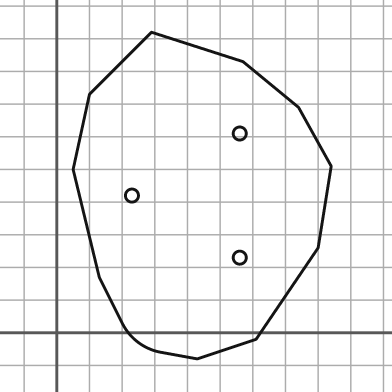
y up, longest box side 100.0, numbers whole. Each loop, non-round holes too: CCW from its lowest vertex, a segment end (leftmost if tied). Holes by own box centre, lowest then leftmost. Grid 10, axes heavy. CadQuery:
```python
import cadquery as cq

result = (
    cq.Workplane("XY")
    .moveTo(43.0, -8.0)
    .lineTo(61.0, -2.0)
    .lineTo(80.0, 26.0)
    .lineTo(84.0, 51.0)
    .lineTo(74.0, 69.0)
    .lineTo(57.0, 83.0)
    .lineTo(29.0, 92.0)
    .lineTo(10.0, 73.0)
    .lineTo(5.0, 50.0)
    .lineTo(13.0, 17.0)
    .lineTo(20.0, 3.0)
    .threePointArc((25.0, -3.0), (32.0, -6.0))
    .close()
    .moveTo(56.0, 23.0)
    .circle(2.0)
    .moveTo(23.0, 42.0)
    .circle(2.0)
    .moveTo(56.0, 61.0)
    .circle(2.0)
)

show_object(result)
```